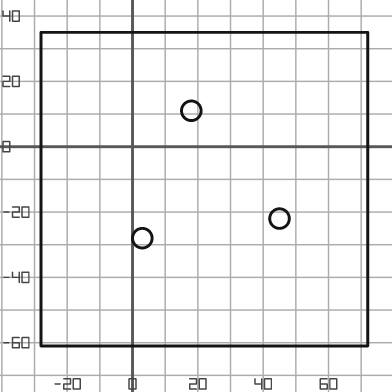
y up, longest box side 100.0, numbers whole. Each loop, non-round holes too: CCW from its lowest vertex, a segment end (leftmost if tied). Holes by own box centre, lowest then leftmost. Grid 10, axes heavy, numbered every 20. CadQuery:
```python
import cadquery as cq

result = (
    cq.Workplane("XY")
    .moveTo(-28.0, -61.0)
    .lineTo(72.0, -61.0)
    .lineTo(72.0, 35.0)
    .lineTo(-28.0, 35.0)
    .close()
    .moveTo(3.0, -28.0)
    .circle(3.0)
    .moveTo(45.0, -22.0)
    .circle(3.0)
    .moveTo(18.0, 11.0)
    .circle(3.0)
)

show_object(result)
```